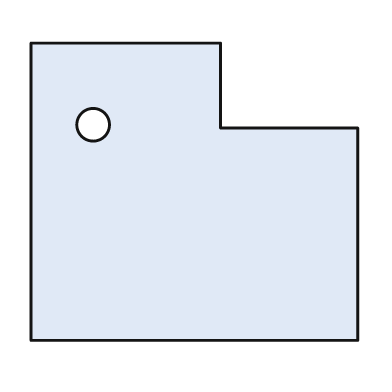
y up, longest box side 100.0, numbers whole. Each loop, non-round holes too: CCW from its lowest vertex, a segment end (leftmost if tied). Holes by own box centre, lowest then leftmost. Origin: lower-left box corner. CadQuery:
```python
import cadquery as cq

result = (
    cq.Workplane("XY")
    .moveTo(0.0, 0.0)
    .lineTo(100.0, 0.0)
    .lineTo(100.0, 65.0)
    .lineTo(58.0, 65.0)
    .lineTo(58.0, 91.0)
    .lineTo(0.0, 91.0)
    .close()
    .moveTo(19.0, 66.0)
    .circle(5.0)
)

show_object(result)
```